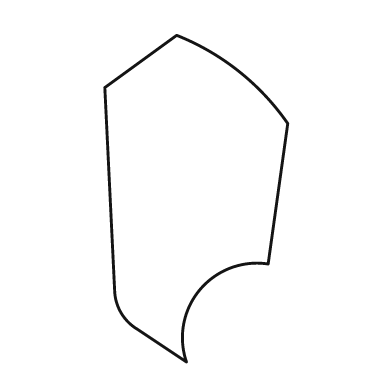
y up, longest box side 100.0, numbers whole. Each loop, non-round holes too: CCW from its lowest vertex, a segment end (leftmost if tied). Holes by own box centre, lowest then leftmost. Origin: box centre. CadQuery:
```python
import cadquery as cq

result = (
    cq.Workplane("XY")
    .moveTo(-3.0, -50.0)
    .threePointArc((1.0, -28.0), (22.0, -20.0))
    .lineTo(28.0, 23.0)
    .threePointArc((13.0, 39.0), (-6.0, 50.0))
    .lineTo(-28.0, 34.0)
    .lineTo(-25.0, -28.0)
    .threePointArc((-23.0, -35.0), (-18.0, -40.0))
    .close()
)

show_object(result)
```